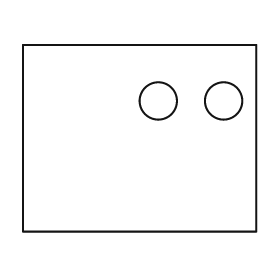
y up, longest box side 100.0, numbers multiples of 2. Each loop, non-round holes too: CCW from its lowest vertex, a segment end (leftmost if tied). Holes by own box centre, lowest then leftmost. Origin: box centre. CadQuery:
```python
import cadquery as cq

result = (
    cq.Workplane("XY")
    .moveTo(-50.0, -40.0)
    .lineTo(50.0, -40.0)
    .lineTo(50.0, 40.0)
    .lineTo(-50.0, 40.0)
    .close()
    .moveTo(8.0, 16.0)
    .circle(8.0)
    .moveTo(36.0, 16.0)
    .circle(8.0)
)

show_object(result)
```